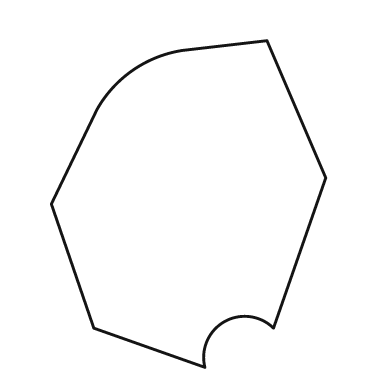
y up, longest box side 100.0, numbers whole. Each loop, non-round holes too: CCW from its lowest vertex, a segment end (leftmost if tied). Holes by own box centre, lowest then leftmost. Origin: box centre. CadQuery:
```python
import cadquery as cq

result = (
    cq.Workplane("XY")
    .moveTo(5.0, -50.0)
    .threePointArc((11.0, -36.0), (26.0, -38.0))
    .lineTo(42.0, 8.0)
    .lineTo(24.0, 50.0)
    .lineTo(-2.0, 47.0)
    .threePointArc((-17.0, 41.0), (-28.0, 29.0))
    .lineTo(-42.0, 0.0)
    .lineTo(-29.0, -38.0)
    .close()
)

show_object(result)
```